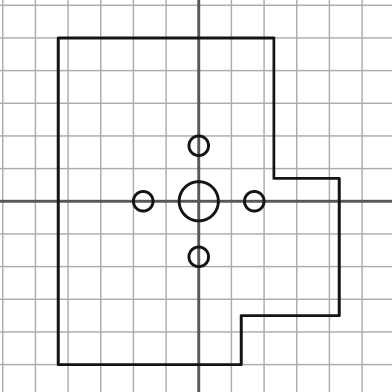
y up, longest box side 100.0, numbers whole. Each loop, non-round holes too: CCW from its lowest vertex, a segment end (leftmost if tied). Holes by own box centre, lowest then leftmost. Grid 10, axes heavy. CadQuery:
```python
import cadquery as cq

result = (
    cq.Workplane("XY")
    .moveTo(-43.0, -50.0)
    .lineTo(13.0, -50.0)
    .lineTo(13.0, -35.0)
    .lineTo(43.0, -35.0)
    .lineTo(43.0, 7.0)
    .lineTo(23.0, 7.0)
    .lineTo(23.0, 50.0)
    .lineTo(-43.0, 50.0)
    .close()
    .moveTo(0.0, -17.0)
    .circle(3.0)
    .moveTo(-17.0, 0.0)
    .circle(3.0)
    .moveTo(0.0, 0.0)
    .circle(6.0)
    .moveTo(17.0, 0.0)
    .circle(3.0)
    .moveTo(0.0, 17.0)
    .circle(3.0)
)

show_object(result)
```